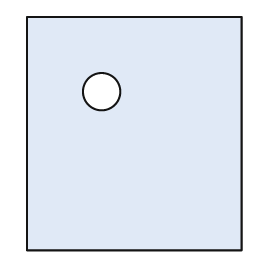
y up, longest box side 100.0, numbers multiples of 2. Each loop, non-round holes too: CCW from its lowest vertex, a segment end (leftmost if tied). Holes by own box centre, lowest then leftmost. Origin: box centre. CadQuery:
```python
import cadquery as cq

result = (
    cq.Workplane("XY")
    .moveTo(-46.0, -50.0)
    .lineTo(46.0, -50.0)
    .lineTo(46.0, 50.0)
    .lineTo(-46.0, 50.0)
    .close()
    .moveTo(-14.0, 18.0)
    .circle(8.0)
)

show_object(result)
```